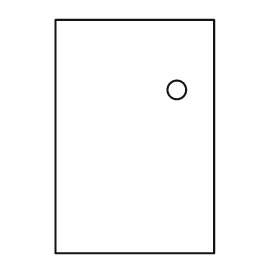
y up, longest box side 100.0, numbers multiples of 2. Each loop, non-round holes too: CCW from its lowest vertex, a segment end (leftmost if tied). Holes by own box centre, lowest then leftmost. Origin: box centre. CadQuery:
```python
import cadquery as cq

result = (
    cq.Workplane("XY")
    .moveTo(-34.0, -50.0)
    .lineTo(34.0, -50.0)
    .lineTo(34.0, 50.0)
    .lineTo(-34.0, 50.0)
    .close()
    .moveTo(18.0, 20.0)
    .circle(4.0)
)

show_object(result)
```